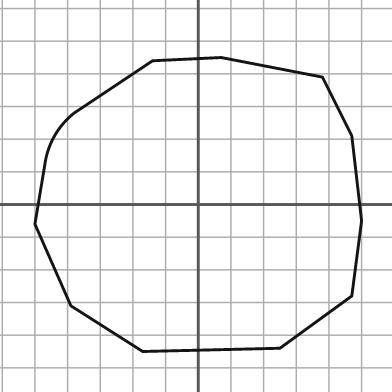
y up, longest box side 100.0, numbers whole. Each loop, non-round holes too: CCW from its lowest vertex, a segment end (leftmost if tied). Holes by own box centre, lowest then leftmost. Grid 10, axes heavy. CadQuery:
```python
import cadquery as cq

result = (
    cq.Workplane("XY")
    .moveTo(-17.0, -45.0)
    .lineTo(25.0, -44.0)
    .lineTo(47.0, -28.0)
    .lineTo(50.0, -5.0)
    .lineTo(47.0, 21.0)
    .lineTo(38.0, 39.0)
    .lineTo(7.0, 45.0)
    .lineTo(-14.0, 44.0)
    .lineTo(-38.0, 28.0)
    .threePointArc((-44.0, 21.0), (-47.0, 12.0))
    .lineTo(-50.0, -6.0)
    .lineTo(-39.0, -31.0)
    .close()
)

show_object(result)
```